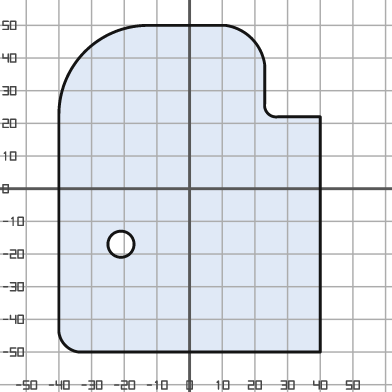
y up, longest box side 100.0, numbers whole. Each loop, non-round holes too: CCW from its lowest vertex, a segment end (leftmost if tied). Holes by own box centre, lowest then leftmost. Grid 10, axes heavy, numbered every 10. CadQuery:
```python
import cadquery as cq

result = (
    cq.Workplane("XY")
    .moveTo(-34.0, -50.0)
    .lineTo(40.0, -50.0)
    .lineTo(40.0, 22.0)
    .lineTo(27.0, 22.0)
    .threePointArc((24.0, 23.0), (23.0, 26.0))
    .lineTo(23.0, 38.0)
    .threePointArc((19.0, 46.0), (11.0, 50.0))
    .lineTo(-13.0, 50.0)
    .threePointArc((-32.0, 42.0), (-40.0, 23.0))
    .lineTo(-40.0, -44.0)
    .threePointArc((-38.0, -48.0), (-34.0, -50.0))
    .close()
    .moveTo(-21.0, -17.0)
    .circle(4.0)
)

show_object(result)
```